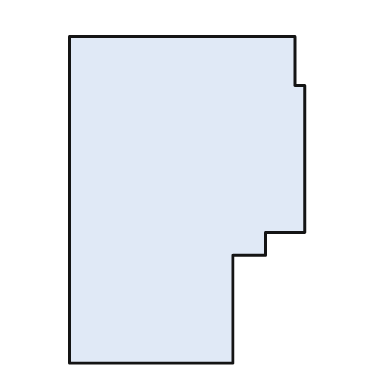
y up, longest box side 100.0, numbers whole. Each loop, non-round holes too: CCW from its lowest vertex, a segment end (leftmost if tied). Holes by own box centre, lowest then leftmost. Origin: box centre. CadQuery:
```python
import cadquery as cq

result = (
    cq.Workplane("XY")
    .moveTo(-36.0, -50.0)
    .lineTo(14.0, -50.0)
    .lineTo(14.0, -17.0)
    .lineTo(24.0, -17.0)
    .lineTo(24.0, -10.0)
    .lineTo(36.0, -10.0)
    .lineTo(36.0, 35.0)
    .lineTo(33.0, 35.0)
    .lineTo(33.0, 50.0)
    .lineTo(-36.0, 50.0)
    .close()
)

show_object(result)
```